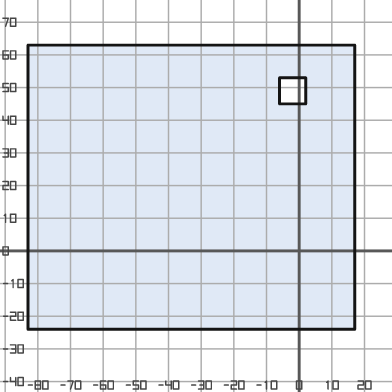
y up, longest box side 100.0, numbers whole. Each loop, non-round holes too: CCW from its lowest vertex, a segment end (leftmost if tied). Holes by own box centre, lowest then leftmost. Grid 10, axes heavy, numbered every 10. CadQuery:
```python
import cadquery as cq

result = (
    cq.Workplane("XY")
    .moveTo(-83.0, -24.0)
    .lineTo(17.0, -24.0)
    .lineTo(17.0, 63.0)
    .lineTo(-83.0, 63.0)
    .close()
    .moveTo(-6.0, 45.0)
    .lineTo(2.0, 45.0)
    .lineTo(2.0, 53.0)
    .lineTo(-6.0, 53.0)
    .close()
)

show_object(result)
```